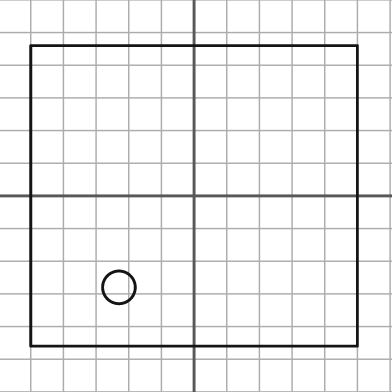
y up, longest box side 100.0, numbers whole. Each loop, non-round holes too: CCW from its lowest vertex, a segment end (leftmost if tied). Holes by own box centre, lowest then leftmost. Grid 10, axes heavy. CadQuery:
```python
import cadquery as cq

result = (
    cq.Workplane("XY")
    .moveTo(-50.0, -46.0)
    .lineTo(50.0, -46.0)
    .lineTo(50.0, 46.0)
    .lineTo(-50.0, 46.0)
    .close()
    .moveTo(-23.0, -28.0)
    .circle(5.0)
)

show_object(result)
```